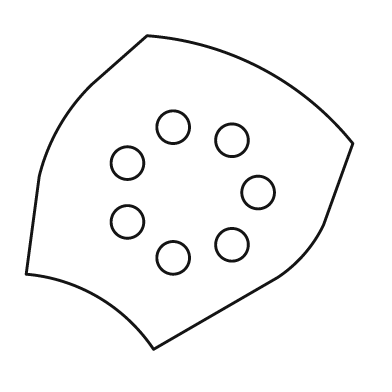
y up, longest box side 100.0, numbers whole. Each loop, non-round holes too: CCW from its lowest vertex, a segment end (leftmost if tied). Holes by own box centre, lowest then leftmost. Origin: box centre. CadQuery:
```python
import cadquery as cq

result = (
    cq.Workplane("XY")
    .moveTo(-11.0, -48.0)
    .lineTo(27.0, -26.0)
    .threePointArc((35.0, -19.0), (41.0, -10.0))
    .lineTo(50.0, 15.0)
    .threePointArc((22.0, 38.0), (-13.0, 48.0))
    .lineTo(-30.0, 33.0)
    .threePointArc((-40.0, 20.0), (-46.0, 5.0))
    .lineTo(-50.0, -25.0)
    .threePointArc((-28.0, -32.0), (-11.0, -48.0))
    .close()
    .moveTo(-5.0, -20.0)
    .circle(5.0)
    .moveTo(13.0, -16.0)
    .circle(5.0)
    .moveTo(-19.0, -9.0)
    .circle(5.0)
    .moveTo(21.0, 0.0)
    .circle(5.0)
    .moveTo(-19.0, 9.0)
    .circle(5.0)
    .moveTo(13.0, 16.0)
    .circle(5.0)
    .moveTo(-5.0, 20.0)
    .circle(5.0)
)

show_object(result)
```